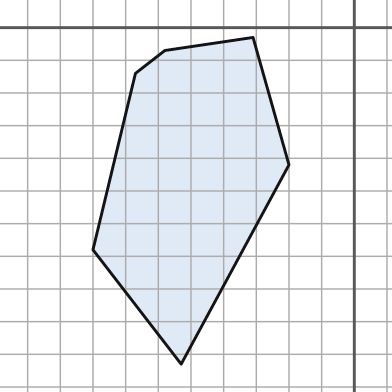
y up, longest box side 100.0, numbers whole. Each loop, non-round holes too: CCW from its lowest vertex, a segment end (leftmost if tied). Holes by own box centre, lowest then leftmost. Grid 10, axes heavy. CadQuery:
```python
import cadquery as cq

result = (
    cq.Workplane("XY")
    .moveTo(-53.0, -103.0)
    .lineTo(-20.0, -42.0)
    .lineTo(-31.0, -3.0)
    .lineTo(-58.0, -7.0)
    .lineTo(-67.0, -14.0)
    .lineTo(-80.0, -68.0)
    .close()
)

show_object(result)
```